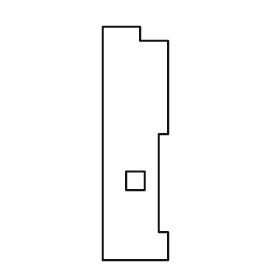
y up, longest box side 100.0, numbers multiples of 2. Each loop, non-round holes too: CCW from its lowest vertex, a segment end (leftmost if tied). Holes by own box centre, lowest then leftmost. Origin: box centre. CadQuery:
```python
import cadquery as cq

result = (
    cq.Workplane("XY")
    .moveTo(-14.0, -50.0)
    .lineTo(14.0, -50.0)
    .lineTo(14.0, -38.0)
    .lineTo(10.0, -38.0)
    .lineTo(10.0, 4.0)
    .lineTo(14.0, 4.0)
    .lineTo(14.0, 44.0)
    .lineTo(2.0, 44.0)
    .lineTo(2.0, 50.0)
    .lineTo(-14.0, 50.0)
    .close()
    .moveTo(-4.0, -20.0)
    .lineTo(4.0, -20.0)
    .lineTo(4.0, -12.0)
    .lineTo(-4.0, -12.0)
    .close()
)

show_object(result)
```